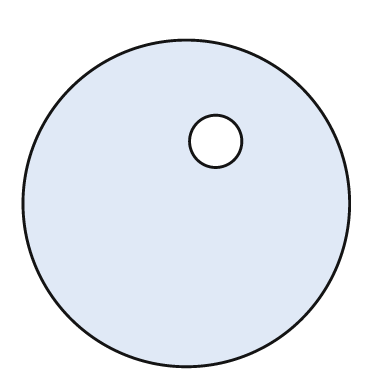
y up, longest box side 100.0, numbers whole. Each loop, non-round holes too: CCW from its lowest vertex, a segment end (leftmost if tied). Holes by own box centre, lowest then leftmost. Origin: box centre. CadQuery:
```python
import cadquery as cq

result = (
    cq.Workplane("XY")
    .moveTo(0.0, 0.0)
    .circle(50.0)
    .moveTo(9.0, 19.0)
    .circle(8.0)
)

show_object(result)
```